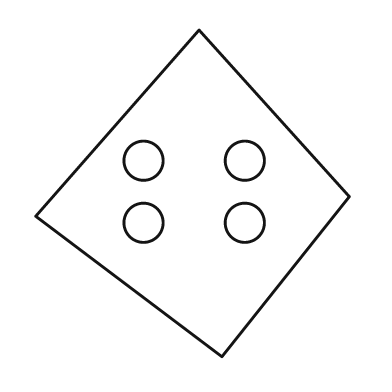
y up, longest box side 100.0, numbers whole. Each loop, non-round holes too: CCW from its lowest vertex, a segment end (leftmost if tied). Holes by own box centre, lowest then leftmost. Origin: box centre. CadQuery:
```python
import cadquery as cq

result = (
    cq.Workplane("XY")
    .moveTo(9.0, -50.0)
    .lineTo(48.0, -1.0)
    .lineTo(2.0, 50.0)
    .lineTo(-48.0, -7.0)
    .close()
    .moveTo(-15.0, -9.0)
    .circle(6.0)
    .moveTo(16.0, -9.0)
    .circle(6.0)
    .moveTo(-15.0, 10.0)
    .circle(6.0)
    .moveTo(16.0, 10.0)
    .circle(6.0)
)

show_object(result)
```